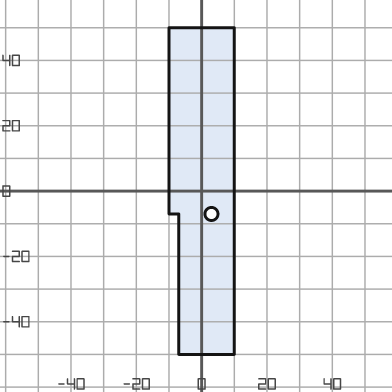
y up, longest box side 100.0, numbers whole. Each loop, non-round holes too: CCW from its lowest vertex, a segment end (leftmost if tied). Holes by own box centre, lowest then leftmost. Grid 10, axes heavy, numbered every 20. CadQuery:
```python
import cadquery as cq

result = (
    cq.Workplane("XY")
    .moveTo(-7.0, -50.0)
    .lineTo(10.0, -50.0)
    .lineTo(10.0, 50.0)
    .lineTo(-10.0, 50.0)
    .lineTo(-10.0, -7.0)
    .lineTo(-7.0, -7.0)
    .close()
    .moveTo(3.0, -7.0)
    .circle(2.0)
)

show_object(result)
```